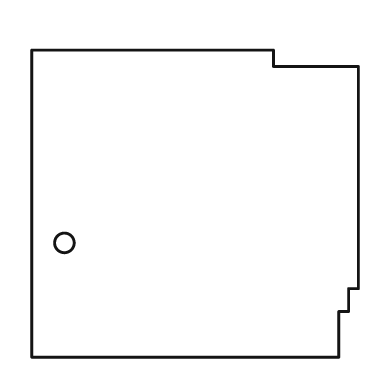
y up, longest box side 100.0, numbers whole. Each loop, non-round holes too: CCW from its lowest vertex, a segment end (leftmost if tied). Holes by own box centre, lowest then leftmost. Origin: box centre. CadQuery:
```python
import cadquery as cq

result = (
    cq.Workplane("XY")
    .moveTo(-50.0, -47.0)
    .lineTo(44.0, -47.0)
    .lineTo(44.0, -33.0)
    .lineTo(47.0, -33.0)
    .lineTo(47.0, -26.0)
    .lineTo(50.0, -26.0)
    .lineTo(50.0, 42.0)
    .lineTo(24.0, 42.0)
    .lineTo(24.0, 47.0)
    .lineTo(-50.0, 47.0)
    .close()
    .moveTo(-40.0, -12.0)
    .circle(3.0)
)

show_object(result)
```